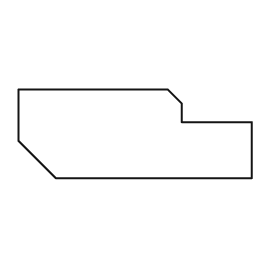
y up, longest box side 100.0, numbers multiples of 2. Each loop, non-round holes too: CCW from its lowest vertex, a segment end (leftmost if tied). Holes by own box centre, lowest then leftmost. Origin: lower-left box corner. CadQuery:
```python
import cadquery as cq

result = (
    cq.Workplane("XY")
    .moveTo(16.0, 0.0)
    .lineTo(100.0, 0.0)
    .lineTo(100.0, 24.0)
    .lineTo(70.0, 24.0)
    .lineTo(70.0, 32.0)
    .lineTo(64.0, 38.0)
    .lineTo(0.0, 38.0)
    .lineTo(0.0, 16.0)
    .close()
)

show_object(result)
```